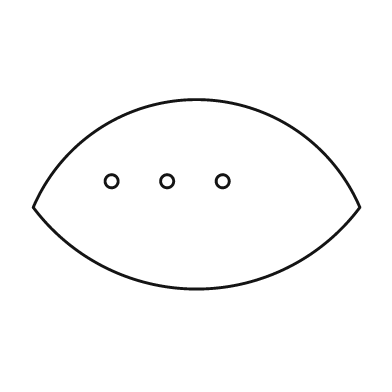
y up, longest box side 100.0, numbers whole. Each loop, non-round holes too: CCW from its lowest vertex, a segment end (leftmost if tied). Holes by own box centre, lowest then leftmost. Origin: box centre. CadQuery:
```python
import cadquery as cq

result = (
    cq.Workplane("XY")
    .moveTo(-50.0, -4.0)
    .threePointArc((0.0, -29.0), (50.0, -4.0))
    .threePointArc((0.0, 29.0), (-50.0, -4.0))
    .close()
    .moveTo(-26.0, 4.0)
    .circle(2.0)
    .moveTo(-9.0, 4.0)
    .circle(2.0)
    .moveTo(8.0, 4.0)
    .circle(2.0)
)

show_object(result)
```